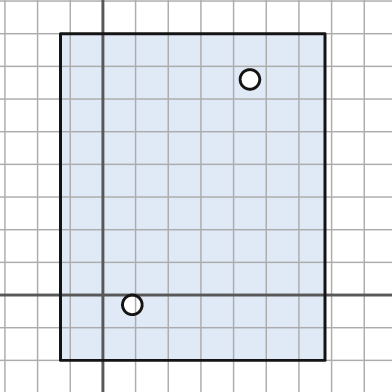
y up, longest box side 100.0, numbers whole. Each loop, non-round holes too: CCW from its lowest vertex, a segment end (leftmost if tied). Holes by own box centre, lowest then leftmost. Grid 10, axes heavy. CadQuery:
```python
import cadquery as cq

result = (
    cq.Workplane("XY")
    .moveTo(-13.0, -20.0)
    .lineTo(68.0, -20.0)
    .lineTo(68.0, 80.0)
    .lineTo(-13.0, 80.0)
    .close()
    .moveTo(9.0, -3.0)
    .circle(3.0)
    .moveTo(45.0, 66.0)
    .circle(3.0)
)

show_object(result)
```